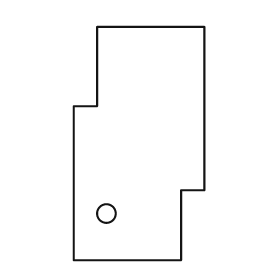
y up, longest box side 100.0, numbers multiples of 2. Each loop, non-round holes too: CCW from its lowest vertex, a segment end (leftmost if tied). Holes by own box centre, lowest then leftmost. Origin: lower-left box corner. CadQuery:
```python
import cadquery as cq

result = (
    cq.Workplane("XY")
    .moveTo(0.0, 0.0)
    .lineTo(46.0, 0.0)
    .lineTo(46.0, 30.0)
    .lineTo(56.0, 30.0)
    .lineTo(56.0, 100.0)
    .lineTo(10.0, 100.0)
    .lineTo(10.0, 66.0)
    .lineTo(0.0, 66.0)
    .close()
    .moveTo(14.0, 20.0)
    .circle(4.0)
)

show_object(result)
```